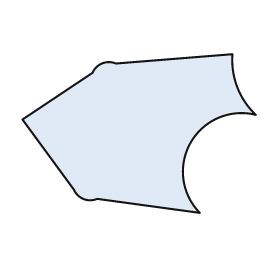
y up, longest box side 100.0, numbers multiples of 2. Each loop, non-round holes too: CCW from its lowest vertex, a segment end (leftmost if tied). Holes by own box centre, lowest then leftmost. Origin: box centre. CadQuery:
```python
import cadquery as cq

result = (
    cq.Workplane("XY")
    .moveTo(26.0, -34.0)
    .threePointArc((22.0, -4.0), (50.0, 8.0))
    .threePointArc((42.0, 20.0), (40.0, 34.0))
    .lineTo(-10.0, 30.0)
    .threePointArc((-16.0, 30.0), (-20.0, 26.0))
    .lineTo(-50.0, 6.0)
    .lineTo(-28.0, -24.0)
    .threePointArc((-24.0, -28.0), (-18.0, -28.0))
    .close()
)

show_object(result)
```